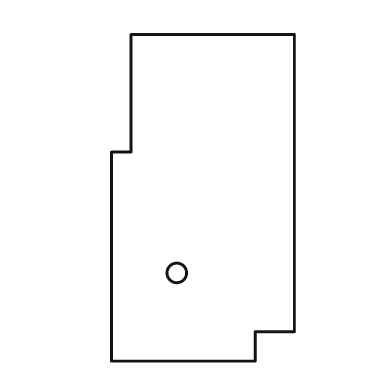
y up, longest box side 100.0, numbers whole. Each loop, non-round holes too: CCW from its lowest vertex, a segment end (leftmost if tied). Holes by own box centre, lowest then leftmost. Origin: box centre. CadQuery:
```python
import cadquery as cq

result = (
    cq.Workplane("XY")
    .moveTo(-28.0, -50.0)
    .lineTo(16.0, -50.0)
    .lineTo(16.0, -41.0)
    .lineTo(28.0, -41.0)
    .lineTo(28.0, 50.0)
    .lineTo(-22.0, 50.0)
    .lineTo(-22.0, 14.0)
    .lineTo(-28.0, 14.0)
    .close()
    .moveTo(-8.0, -23.0)
    .circle(3.0)
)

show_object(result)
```